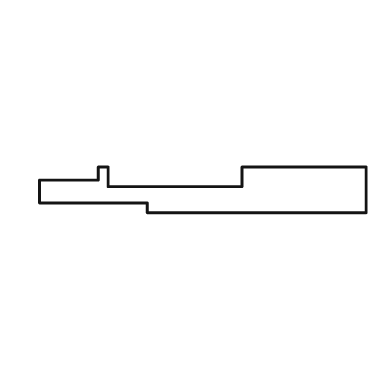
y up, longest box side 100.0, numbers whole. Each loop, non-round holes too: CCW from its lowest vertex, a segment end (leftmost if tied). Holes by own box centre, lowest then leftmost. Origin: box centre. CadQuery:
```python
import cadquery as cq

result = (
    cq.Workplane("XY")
    .moveTo(-17.0, -7.0)
    .lineTo(50.0, -7.0)
    .lineTo(50.0, 7.0)
    .lineTo(12.0, 7.0)
    .lineTo(12.0, 1.0)
    .lineTo(-29.0, 1.0)
    .lineTo(-29.0, 7.0)
    .lineTo(-32.0, 7.0)
    .lineTo(-32.0, 3.0)
    .lineTo(-50.0, 3.0)
    .lineTo(-50.0, -4.0)
    .lineTo(-17.0, -4.0)
    .close()
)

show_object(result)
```